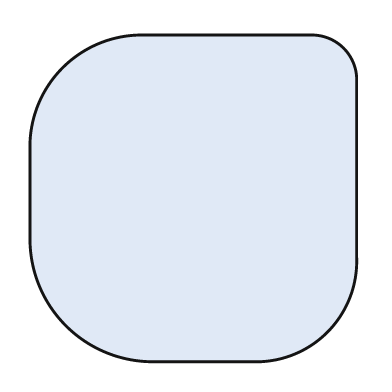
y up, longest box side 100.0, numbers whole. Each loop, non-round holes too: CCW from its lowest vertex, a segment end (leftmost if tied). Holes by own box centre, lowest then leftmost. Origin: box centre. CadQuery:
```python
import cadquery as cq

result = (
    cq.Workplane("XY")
    .moveTo(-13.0, -50.0)
    .lineTo(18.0, -50.0)
    .threePointArc((41.0, -41.0), (50.0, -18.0))
    .lineTo(50.0, 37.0)
    .threePointArc((46.0, 46.0), (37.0, 50.0))
    .lineTo(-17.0, 50.0)
    .threePointArc((-40.0, 40.0), (-50.0, 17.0))
    .lineTo(-50.0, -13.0)
    .threePointArc((-39.0, -39.0), (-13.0, -50.0))
    .close()
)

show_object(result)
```